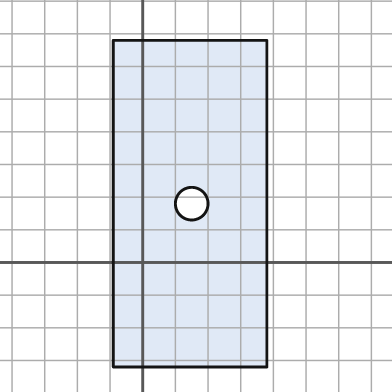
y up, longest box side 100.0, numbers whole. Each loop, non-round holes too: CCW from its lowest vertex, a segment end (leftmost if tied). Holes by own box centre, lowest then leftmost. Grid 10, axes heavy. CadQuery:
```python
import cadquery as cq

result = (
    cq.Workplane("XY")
    .moveTo(-9.0, -32.0)
    .lineTo(38.0, -32.0)
    .lineTo(38.0, 68.0)
    .lineTo(-9.0, 68.0)
    .close()
    .moveTo(15.0, 18.0)
    .circle(5.0)
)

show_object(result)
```